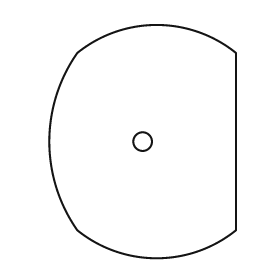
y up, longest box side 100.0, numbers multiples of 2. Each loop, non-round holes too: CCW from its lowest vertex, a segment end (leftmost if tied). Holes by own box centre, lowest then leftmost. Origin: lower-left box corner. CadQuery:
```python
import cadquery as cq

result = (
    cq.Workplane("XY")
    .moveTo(12.0, 12.0)
    .threePointArc((46.0, 0.0), (80.0, 12.0))
    .lineTo(80.0, 88.0)
    .threePointArc((46.0, 100.0), (12.0, 88.0))
    .threePointArc((0.0, 50.0), (12.0, 12.0))
    .close()
    .moveTo(40.0, 50.0)
    .circle(4.0)
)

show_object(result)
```